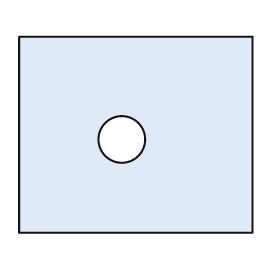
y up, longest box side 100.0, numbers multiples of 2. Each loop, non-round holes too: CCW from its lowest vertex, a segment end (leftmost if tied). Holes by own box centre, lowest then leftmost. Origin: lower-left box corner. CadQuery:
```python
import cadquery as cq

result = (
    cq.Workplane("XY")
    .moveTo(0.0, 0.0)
    .lineTo(100.0, 0.0)
    .lineTo(100.0, 84.0)
    .lineTo(0.0, 84.0)
    .close()
    .moveTo(44.0, 40.0)
    .circle(10.0)
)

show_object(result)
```